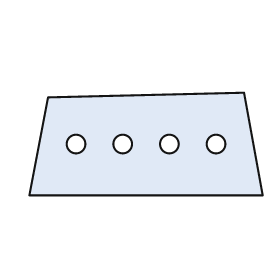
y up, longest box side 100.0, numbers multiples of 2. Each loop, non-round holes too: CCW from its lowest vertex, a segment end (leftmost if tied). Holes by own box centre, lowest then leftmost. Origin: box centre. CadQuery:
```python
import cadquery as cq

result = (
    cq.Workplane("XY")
    .moveTo(-50.0, -22.0)
    .lineTo(50.0, -22.0)
    .lineTo(42.0, 22.0)
    .lineTo(-42.0, 20.0)
    .close()
    .moveTo(-30.0, 0.0)
    .circle(4.0)
    .moveTo(-10.0, 0.0)
    .circle(4.0)
    .moveTo(10.0, 0.0)
    .circle(4.0)
    .moveTo(30.0, 0.0)
    .circle(4.0)
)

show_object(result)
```